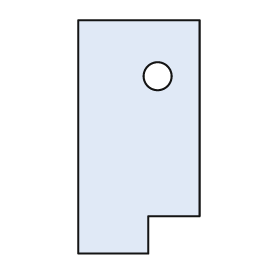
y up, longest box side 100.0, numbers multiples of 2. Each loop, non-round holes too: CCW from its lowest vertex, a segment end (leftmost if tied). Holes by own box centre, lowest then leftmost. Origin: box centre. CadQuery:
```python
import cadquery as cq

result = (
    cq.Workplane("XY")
    .moveTo(-26.0, -50.0)
    .lineTo(4.0, -50.0)
    .lineTo(4.0, -34.0)
    .lineTo(26.0, -34.0)
    .lineTo(26.0, 50.0)
    .lineTo(-26.0, 50.0)
    .close()
    .moveTo(8.0, 26.0)
    .circle(6.0)
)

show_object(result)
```